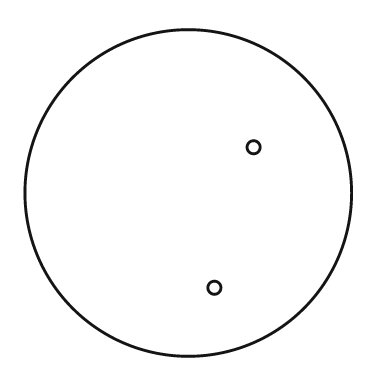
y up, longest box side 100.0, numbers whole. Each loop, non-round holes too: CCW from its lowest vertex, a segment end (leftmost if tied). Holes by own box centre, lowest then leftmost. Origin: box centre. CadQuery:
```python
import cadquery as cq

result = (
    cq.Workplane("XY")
    .moveTo(0.0, 0.0)
    .circle(50.0)
    .moveTo(8.0, -29.0)
    .circle(2.0)
    .moveTo(20.0, 14.0)
    .circle(2.0)
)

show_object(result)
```